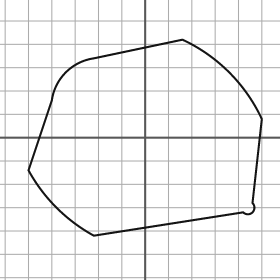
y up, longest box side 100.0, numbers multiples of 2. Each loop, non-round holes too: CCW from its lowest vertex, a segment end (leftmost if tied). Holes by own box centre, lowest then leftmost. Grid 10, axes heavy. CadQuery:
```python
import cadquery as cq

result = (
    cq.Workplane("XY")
    .moveTo(-22.0, -42.0)
    .lineTo(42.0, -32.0)
    .threePointArc((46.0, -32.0), (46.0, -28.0))
    .lineTo(50.0, 8.0)
    .threePointArc((36.0, 28.0), (16.0, 42.0))
    .lineTo(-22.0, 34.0)
    .threePointArc((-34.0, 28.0), (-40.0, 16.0))
    .lineTo(-50.0, -14.0)
    .threePointArc((-38.0, -30.0), (-22.0, -42.0))
    .close()
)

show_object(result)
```